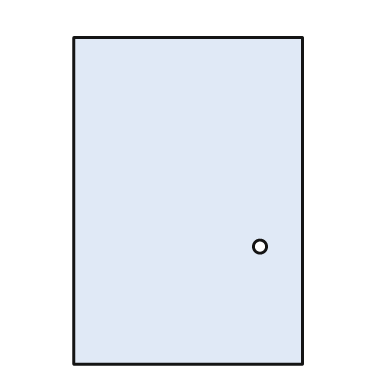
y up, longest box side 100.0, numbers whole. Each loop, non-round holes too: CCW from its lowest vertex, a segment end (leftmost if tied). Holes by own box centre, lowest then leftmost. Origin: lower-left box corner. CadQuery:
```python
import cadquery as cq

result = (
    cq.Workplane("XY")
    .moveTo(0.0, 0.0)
    .lineTo(70.0, 0.0)
    .lineTo(70.0, 100.0)
    .lineTo(0.0, 100.0)
    .close()
    .moveTo(57.0, 36.0)
    .circle(2.0)
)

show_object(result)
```